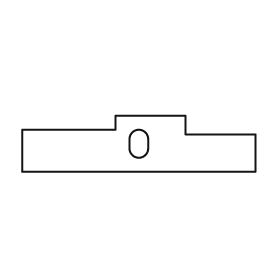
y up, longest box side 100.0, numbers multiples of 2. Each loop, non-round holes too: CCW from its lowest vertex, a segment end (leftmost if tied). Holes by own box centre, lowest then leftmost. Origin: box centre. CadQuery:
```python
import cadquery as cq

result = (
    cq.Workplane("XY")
    .moveTo(-50.0, -12.0)
    .lineTo(50.0, -12.0)
    .lineTo(50.0, 4.0)
    .lineTo(20.0, 4.0)
    .lineTo(20.0, 12.0)
    .lineTo(-10.0, 12.0)
    .lineTo(-10.0, 6.0)
    .lineTo(-50.0, 6.0)
    .close()
    .moveTo(-4.0, -2.0)
    .threePointArc((0.0, -6.0), (4.0, -2.0))
    .lineTo(4.0, 2.0)
    .threePointArc((0.0, 6.0), (-4.0, 2.0))
    .close()
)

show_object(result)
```